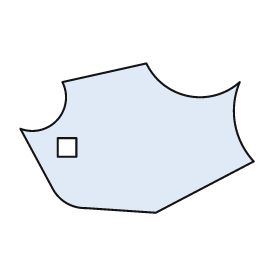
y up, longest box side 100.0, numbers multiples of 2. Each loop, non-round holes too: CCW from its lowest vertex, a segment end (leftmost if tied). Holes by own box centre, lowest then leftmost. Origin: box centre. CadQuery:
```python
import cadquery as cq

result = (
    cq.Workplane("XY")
    .moveTo(8.0, -32.0)
    .lineTo(50.0, -10.0)
    .threePointArc((42.0, 6.0), (44.0, 24.0))
    .threePointArc((22.0, 18.0), (4.0, 32.0))
    .lineTo(-32.0, 24.0)
    .threePointArc((-34.0, 8.0), (-50.0, 4.0))
    .lineTo(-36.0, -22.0)
    .threePointArc((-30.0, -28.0), (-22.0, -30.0))
    .close()
    .moveTo(-34.0, -8.0)
    .lineTo(-26.0, -8.0)
    .lineTo(-26.0, 0.0)
    .lineTo(-34.0, 0.0)
    .close()
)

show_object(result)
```